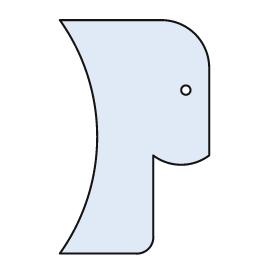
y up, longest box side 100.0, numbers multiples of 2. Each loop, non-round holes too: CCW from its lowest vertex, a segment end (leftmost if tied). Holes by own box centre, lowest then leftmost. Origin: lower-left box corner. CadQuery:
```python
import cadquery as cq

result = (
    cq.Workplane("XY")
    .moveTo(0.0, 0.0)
    .lineTo(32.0, 0.0)
    .threePointArc((38.0, 2.0), (40.0, 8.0))
    .lineTo(40.0, 42.0)
    .threePointArc((52.0, 38.0), (64.0, 42.0))
    .lineTo(64.0, 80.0)
    .threePointArc((58.0, 94.0), (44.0, 100.0))
    .lineTo(0.0, 100.0)
    .threePointArc((16.0, 50.0), (0.0, 0.0))
    .close()
    .moveTo(54.0, 70.0)
    .circle(2.0)
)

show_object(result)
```